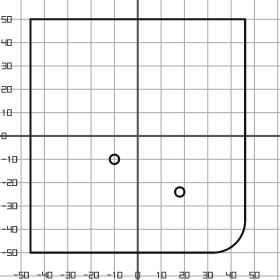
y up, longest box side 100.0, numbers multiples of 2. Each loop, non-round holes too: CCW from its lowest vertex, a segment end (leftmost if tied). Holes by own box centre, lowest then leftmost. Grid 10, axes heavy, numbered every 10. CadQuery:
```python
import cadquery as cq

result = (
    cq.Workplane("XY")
    .moveTo(-46.0, -50.0)
    .lineTo(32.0, -50.0)
    .threePointArc((42.0, -46.0), (46.0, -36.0))
    .lineTo(46.0, 50.0)
    .lineTo(-46.0, 50.0)
    .close()
    .moveTo(18.0, -24.0)
    .circle(2.0)
    .moveTo(-10.0, -10.0)
    .circle(2.0)
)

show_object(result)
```